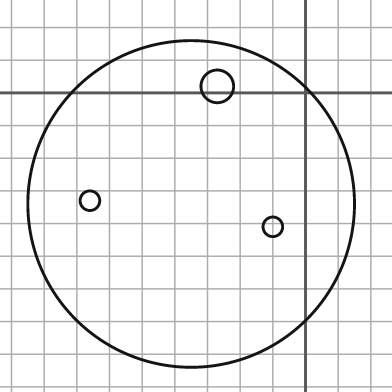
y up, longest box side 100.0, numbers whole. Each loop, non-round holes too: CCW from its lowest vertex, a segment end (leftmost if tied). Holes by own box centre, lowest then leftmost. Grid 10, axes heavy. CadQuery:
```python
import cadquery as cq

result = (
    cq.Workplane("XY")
    .moveTo(-35.0, -34.0)
    .circle(50.0)
    .moveTo(-10.0, -41.0)
    .circle(3.0)
    .moveTo(-66.0, -33.0)
    .circle(3.0)
    .moveTo(-27.0, 2.0)
    .circle(5.0)
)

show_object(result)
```